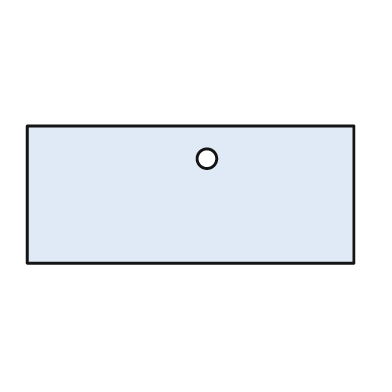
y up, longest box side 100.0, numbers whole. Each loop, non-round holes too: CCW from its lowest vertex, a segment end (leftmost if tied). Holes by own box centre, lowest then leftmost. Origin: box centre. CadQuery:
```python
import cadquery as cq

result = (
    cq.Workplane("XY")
    .moveTo(-50.0, -21.0)
    .lineTo(50.0, -21.0)
    .lineTo(50.0, 21.0)
    .lineTo(-50.0, 21.0)
    .close()
    .moveTo(5.0, 11.0)
    .circle(3.0)
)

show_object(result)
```